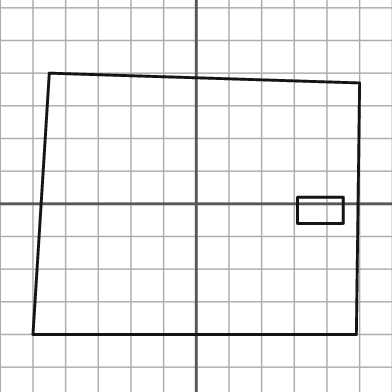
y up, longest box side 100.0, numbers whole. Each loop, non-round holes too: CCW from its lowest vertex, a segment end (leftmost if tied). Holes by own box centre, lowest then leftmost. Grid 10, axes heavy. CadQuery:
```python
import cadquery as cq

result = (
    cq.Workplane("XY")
    .moveTo(-50.0, -40.0)
    .lineTo(49.0, -40.0)
    .lineTo(50.0, 37.0)
    .lineTo(-45.0, 40.0)
    .close()
    .moveTo(31.0, -6.0)
    .lineTo(45.0, -6.0)
    .lineTo(45.0, 2.0)
    .lineTo(31.0, 2.0)
    .close()
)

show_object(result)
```